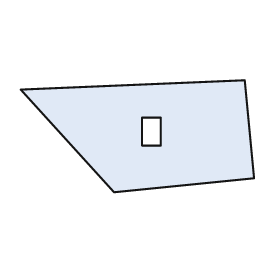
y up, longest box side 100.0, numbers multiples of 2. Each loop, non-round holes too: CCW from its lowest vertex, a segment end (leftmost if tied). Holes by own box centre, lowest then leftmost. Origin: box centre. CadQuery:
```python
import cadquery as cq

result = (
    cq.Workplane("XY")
    .moveTo(-10.0, -24.0)
    .lineTo(50.0, -18.0)
    .lineTo(46.0, 24.0)
    .lineTo(-50.0, 20.0)
    .close()
    .moveTo(2.0, -4.0)
    .lineTo(10.0, -4.0)
    .lineTo(10.0, 8.0)
    .lineTo(2.0, 8.0)
    .close()
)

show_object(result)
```